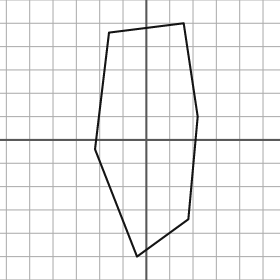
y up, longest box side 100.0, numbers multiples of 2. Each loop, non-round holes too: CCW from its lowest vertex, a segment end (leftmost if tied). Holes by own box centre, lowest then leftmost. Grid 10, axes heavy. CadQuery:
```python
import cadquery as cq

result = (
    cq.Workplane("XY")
    .moveTo(-4.0, -50.0)
    .lineTo(18.0, -34.0)
    .lineTo(22.0, 10.0)
    .lineTo(16.0, 50.0)
    .lineTo(-16.0, 46.0)
    .lineTo(-22.0, -4.0)
    .close()
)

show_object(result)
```